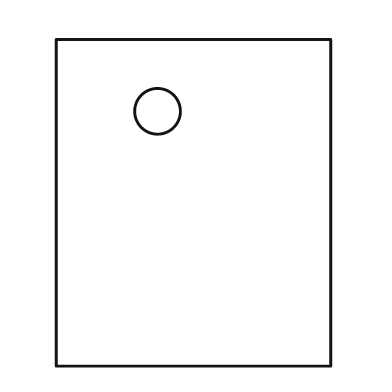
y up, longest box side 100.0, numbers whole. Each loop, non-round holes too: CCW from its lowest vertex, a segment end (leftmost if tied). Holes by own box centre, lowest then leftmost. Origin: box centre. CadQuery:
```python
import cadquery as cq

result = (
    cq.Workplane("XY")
    .moveTo(-42.0, -50.0)
    .lineTo(42.0, -50.0)
    .lineTo(42.0, 50.0)
    .lineTo(-42.0, 50.0)
    .close()
    .moveTo(-11.0, 28.0)
    .circle(7.0)
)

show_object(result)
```